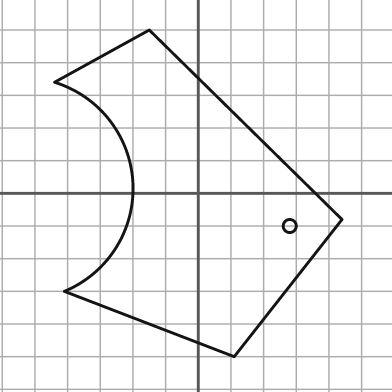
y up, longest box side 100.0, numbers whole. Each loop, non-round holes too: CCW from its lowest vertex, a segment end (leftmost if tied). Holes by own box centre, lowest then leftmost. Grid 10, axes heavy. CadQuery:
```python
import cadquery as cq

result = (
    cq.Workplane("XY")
    .moveTo(11.0, -50.0)
    .lineTo(44.0, -8.0)
    .lineTo(-15.0, 50.0)
    .lineTo(-44.0, 34.0)
    .threePointArc((-20.0, 3.0), (-41.0, -30.0))
    .close()
    .moveTo(28.0, -10.0)
    .circle(2.0)
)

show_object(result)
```